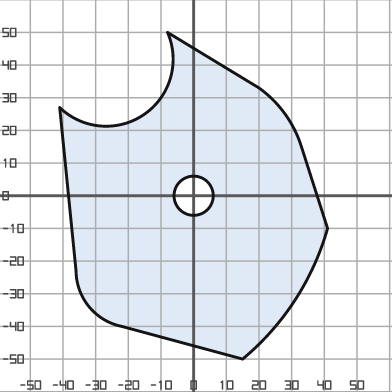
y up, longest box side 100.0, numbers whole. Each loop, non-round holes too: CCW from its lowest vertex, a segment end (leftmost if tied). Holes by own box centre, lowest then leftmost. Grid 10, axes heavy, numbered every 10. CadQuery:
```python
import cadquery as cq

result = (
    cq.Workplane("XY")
    .moveTo(15.0, -50.0)
    .threePointArc((31.0, -32.0), (41.0, -10.0))
    .lineTo(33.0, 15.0)
    .threePointArc((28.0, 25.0), (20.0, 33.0))
    .lineTo(-8.0, 50.0)
    .threePointArc((-15.0, 25.0), (-41.0, 27.0))
    .lineTo(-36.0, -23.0)
    .threePointArc((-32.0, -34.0), (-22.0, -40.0))
    .close()
    .moveTo(0.0, 0.0)
    .circle(6.0)
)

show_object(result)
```